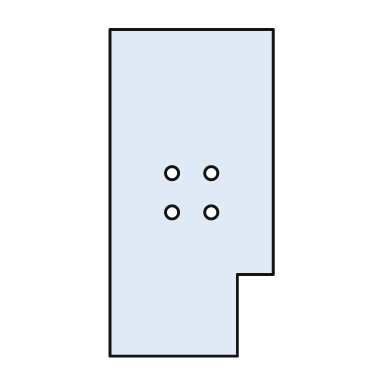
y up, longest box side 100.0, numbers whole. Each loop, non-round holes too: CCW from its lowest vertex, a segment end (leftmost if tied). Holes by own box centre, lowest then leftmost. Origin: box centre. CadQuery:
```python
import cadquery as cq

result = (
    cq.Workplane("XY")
    .moveTo(-25.0, -50.0)
    .lineTo(14.0, -50.0)
    .lineTo(14.0, -25.0)
    .lineTo(25.0, -25.0)
    .lineTo(25.0, 50.0)
    .lineTo(-25.0, 50.0)
    .close()
    .moveTo(-6.0, -6.0)
    .circle(2.0)
    .moveTo(6.0, -6.0)
    .circle(2.0)
    .moveTo(-6.0, 6.0)
    .circle(2.0)
    .moveTo(6.0, 6.0)
    .circle(2.0)
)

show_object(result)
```